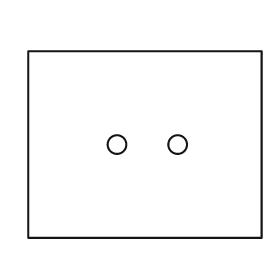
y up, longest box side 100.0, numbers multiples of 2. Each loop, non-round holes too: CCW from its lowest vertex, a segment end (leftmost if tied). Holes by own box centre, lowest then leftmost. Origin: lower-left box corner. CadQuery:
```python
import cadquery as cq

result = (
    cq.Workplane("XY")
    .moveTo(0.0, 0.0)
    .lineTo(100.0, 0.0)
    .lineTo(100.0, 80.0)
    .lineTo(0.0, 80.0)
    .close()
    .moveTo(38.0, 40.0)
    .circle(4.0)
    .moveTo(64.0, 40.0)
    .circle(4.0)
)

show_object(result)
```